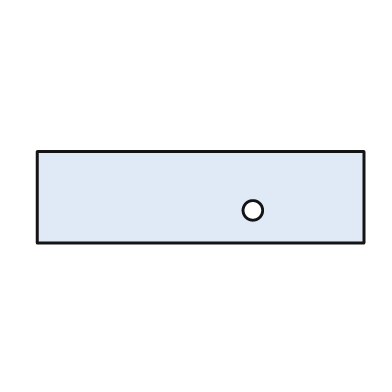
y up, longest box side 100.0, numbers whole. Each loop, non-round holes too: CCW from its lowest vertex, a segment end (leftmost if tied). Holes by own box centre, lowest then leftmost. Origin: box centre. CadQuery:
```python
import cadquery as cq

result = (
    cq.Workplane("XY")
    .moveTo(-50.0, -14.0)
    .lineTo(50.0, -14.0)
    .lineTo(50.0, 14.0)
    .lineTo(-50.0, 14.0)
    .close()
    .moveTo(16.0, -4.0)
    .circle(3.0)
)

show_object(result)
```